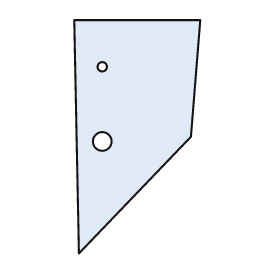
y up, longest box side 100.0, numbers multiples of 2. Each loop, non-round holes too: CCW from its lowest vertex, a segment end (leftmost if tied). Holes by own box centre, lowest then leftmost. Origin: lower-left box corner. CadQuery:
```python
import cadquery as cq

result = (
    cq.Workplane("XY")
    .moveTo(2.0, 0.0)
    .lineTo(50.0, 50.0)
    .lineTo(54.0, 100.0)
    .lineTo(0.0, 100.0)
    .close()
    .moveTo(12.0, 48.0)
    .circle(4.0)
    .moveTo(12.0, 80.0)
    .circle(2.0)
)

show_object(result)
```